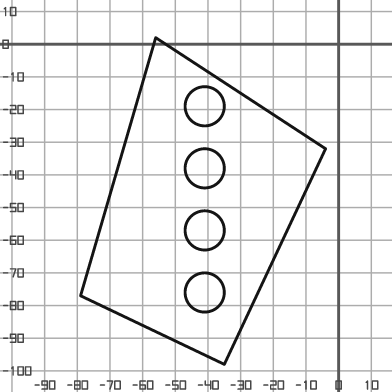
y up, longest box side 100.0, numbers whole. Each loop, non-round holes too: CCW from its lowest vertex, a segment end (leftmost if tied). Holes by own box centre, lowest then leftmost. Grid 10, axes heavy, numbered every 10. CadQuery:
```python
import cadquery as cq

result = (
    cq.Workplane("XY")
    .moveTo(-35.0, -98.0)
    .lineTo(-4.0, -32.0)
    .lineTo(-56.0, 2.0)
    .lineTo(-79.0, -77.0)
    .close()
    .moveTo(-41.0, -76.0)
    .circle(6.0)
    .moveTo(-41.0, -57.0)
    .circle(6.0)
    .moveTo(-41.0, -38.0)
    .circle(6.0)
    .moveTo(-41.0, -19.0)
    .circle(6.0)
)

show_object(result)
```